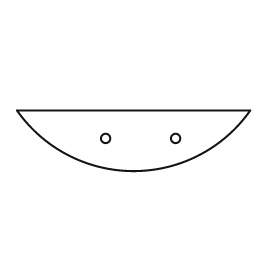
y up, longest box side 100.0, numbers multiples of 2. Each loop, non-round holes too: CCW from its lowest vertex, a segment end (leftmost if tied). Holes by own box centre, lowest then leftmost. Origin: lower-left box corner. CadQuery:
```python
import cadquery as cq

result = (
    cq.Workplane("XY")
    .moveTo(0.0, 26.0)
    .threePointArc((50.0, 0.0), (100.0, 26.0))
    .close()
    .moveTo(38.0, 14.0)
    .circle(2.0)
    .moveTo(68.0, 14.0)
    .circle(2.0)
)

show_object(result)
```